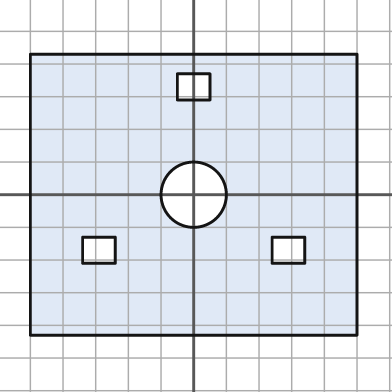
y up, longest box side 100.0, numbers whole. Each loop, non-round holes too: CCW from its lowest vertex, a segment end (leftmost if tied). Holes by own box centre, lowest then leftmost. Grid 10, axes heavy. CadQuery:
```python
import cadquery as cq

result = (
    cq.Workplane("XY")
    .moveTo(-50.0, -43.0)
    .lineTo(50.0, -43.0)
    .lineTo(50.0, 43.0)
    .lineTo(-50.0, 43.0)
    .close()
    .moveTo(-34.0, -21.0)
    .lineTo(-24.0, -21.0)
    .lineTo(-24.0, -13.0)
    .lineTo(-34.0, -13.0)
    .close()
    .moveTo(24.0, -21.0)
    .lineTo(34.0, -21.0)
    .lineTo(34.0, -13.0)
    .lineTo(24.0, -13.0)
    .close()
    .moveTo(0.0, 0.0)
    .circle(10.0)
    .moveTo(-5.0, 29.0)
    .lineTo(5.0, 29.0)
    .lineTo(5.0, 37.0)
    .lineTo(-5.0, 37.0)
    .close()
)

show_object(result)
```